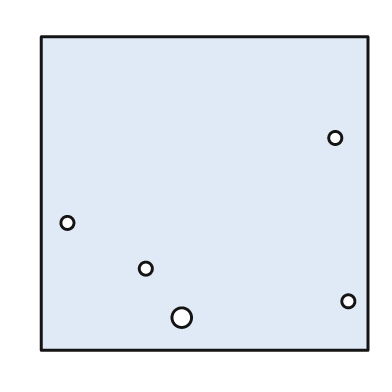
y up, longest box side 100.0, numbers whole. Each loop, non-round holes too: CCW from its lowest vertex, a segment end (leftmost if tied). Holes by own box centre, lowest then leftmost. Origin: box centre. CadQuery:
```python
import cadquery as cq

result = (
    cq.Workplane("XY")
    .moveTo(-50.0, -48.0)
    .lineTo(50.0, -48.0)
    .lineTo(50.0, 48.0)
    .lineTo(-50.0, 48.0)
    .close()
    .moveTo(-7.0, -38.0)
    .circle(3.0)
    .moveTo(44.0, -33.0)
    .circle(2.0)
    .moveTo(-18.0, -23.0)
    .circle(2.0)
    .moveTo(-42.0, -9.0)
    .circle(2.0)
    .moveTo(40.0, 17.0)
    .circle(2.0)
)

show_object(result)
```